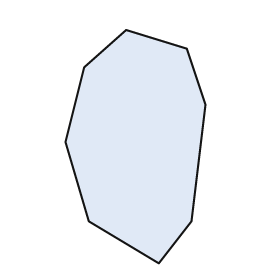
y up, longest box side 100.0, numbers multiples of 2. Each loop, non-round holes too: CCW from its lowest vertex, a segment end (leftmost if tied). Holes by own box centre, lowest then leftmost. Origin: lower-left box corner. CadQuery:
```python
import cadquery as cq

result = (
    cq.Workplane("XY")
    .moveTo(40.0, 0.0)
    .lineTo(54.0, 18.0)
    .lineTo(60.0, 68.0)
    .lineTo(52.0, 92.0)
    .lineTo(26.0, 100.0)
    .lineTo(8.0, 84.0)
    .lineTo(0.0, 52.0)
    .lineTo(10.0, 18.0)
    .close()
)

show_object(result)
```